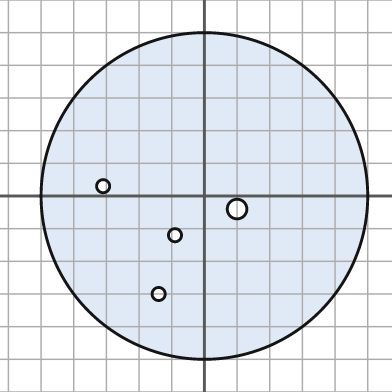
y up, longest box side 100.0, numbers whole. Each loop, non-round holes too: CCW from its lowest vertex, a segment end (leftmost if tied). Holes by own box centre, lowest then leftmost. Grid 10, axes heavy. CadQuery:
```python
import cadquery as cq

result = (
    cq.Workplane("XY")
    .moveTo(0.0, 0.0)
    .circle(50.0)
    .moveTo(-14.0, -30.0)
    .circle(2.0)
    .moveTo(-9.0, -12.0)
    .circle(2.0)
    .moveTo(10.0, -4.0)
    .circle(3.0)
    .moveTo(-31.0, 3.0)
    .circle(2.0)
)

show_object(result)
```